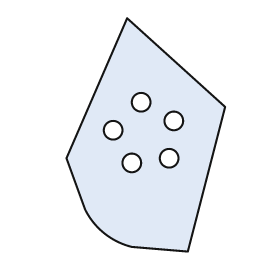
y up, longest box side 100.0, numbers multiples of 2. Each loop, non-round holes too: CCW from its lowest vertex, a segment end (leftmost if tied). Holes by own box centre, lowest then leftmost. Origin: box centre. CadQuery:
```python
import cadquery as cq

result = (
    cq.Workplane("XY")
    .moveTo(18.0, -50.0)
    .lineTo(34.0, 12.0)
    .lineTo(-8.0, 50.0)
    .lineTo(-34.0, -10.0)
    .lineTo(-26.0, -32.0)
    .threePointArc((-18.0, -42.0), (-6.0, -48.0))
    .close()
    .moveTo(-6.0, -12.0)
    .circle(4.0)
    .moveTo(10.0, -10.0)
    .circle(4.0)
    .moveTo(-14.0, 2.0)
    .circle(4.0)
    .moveTo(12.0, 6.0)
    .circle(4.0)
    .moveTo(-2.0, 14.0)
    .circle(4.0)
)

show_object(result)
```